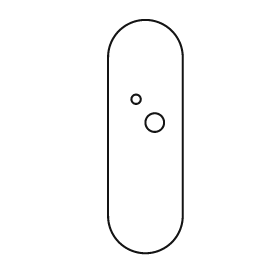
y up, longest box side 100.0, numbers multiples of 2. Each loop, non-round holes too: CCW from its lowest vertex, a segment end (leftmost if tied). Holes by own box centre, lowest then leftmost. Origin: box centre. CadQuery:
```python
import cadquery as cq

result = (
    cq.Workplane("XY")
    .moveTo(-16.0, -34.0)
    .threePointArc((0.0, -50.0), (16.0, -34.0))
    .lineTo(16.0, 34.0)
    .threePointArc((0.0, 50.0), (-16.0, 34.0))
    .close()
    .moveTo(4.0, 6.0)
    .circle(4.0)
    .moveTo(-4.0, 16.0)
    .circle(2.0)
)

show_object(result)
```